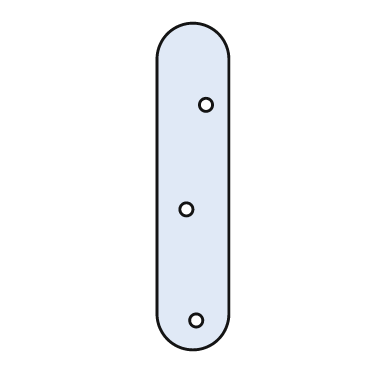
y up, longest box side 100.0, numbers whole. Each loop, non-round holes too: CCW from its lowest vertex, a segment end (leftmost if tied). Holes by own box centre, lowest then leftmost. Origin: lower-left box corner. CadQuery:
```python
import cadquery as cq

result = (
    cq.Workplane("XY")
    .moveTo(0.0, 11.0)
    .threePointArc((11.0, 0.0), (22.0, 11.0))
    .lineTo(22.0, 89.0)
    .threePointArc((11.0, 100.0), (0.0, 89.0))
    .close()
    .moveTo(12.0, 9.0)
    .circle(2.0)
    .moveTo(9.0, 43.0)
    .circle(2.0)
    .moveTo(15.0, 75.0)
    .circle(2.0)
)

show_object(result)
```